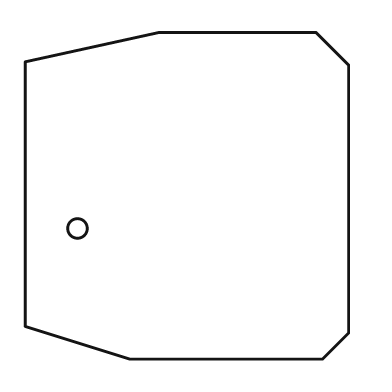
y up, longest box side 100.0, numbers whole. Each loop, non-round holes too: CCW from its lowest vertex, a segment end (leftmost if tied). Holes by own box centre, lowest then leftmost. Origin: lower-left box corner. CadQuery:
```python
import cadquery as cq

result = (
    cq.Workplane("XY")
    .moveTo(32.0, 0.0)
    .lineTo(91.0, 0.0)
    .lineTo(99.0, 8.0)
    .lineTo(99.0, 90.0)
    .lineTo(89.0, 100.0)
    .lineTo(41.0, 100.0)
    .lineTo(0.0, 91.0)
    .lineTo(0.0, 10.0)
    .close()
    .moveTo(16.0, 40.0)
    .circle(3.0)
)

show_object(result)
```